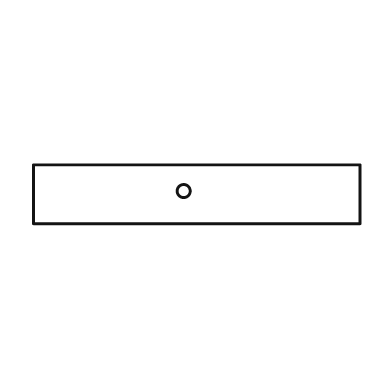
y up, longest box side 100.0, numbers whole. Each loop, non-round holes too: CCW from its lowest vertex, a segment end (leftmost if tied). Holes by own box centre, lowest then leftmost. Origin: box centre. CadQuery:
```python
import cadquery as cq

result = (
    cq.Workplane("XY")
    .moveTo(-50.0, -9.0)
    .lineTo(50.0, -9.0)
    .lineTo(50.0, 9.0)
    .lineTo(-50.0, 9.0)
    .close()
    .moveTo(-4.0, 1.0)
    .circle(2.0)
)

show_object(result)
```